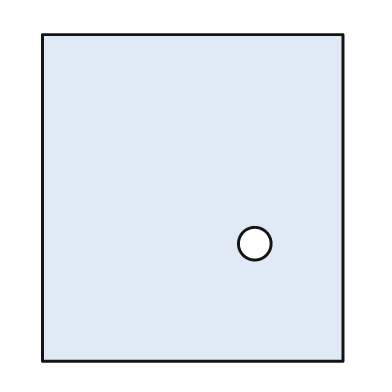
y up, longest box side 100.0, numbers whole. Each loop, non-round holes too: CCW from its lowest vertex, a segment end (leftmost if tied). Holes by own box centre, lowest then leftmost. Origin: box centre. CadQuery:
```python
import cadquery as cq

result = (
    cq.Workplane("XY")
    .moveTo(-46.0, -50.0)
    .lineTo(46.0, -50.0)
    .lineTo(46.0, 50.0)
    .lineTo(-46.0, 50.0)
    .close()
    .moveTo(19.0, -14.0)
    .circle(5.0)
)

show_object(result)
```